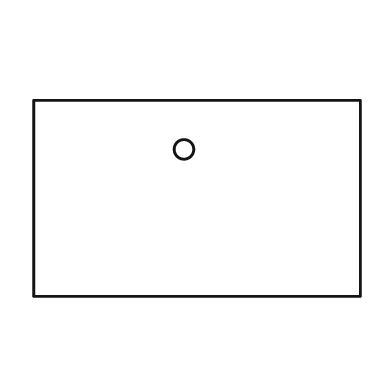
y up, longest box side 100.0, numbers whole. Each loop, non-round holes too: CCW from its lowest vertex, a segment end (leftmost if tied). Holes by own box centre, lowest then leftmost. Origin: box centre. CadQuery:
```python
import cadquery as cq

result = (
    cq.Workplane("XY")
    .moveTo(-50.0, -30.0)
    .lineTo(50.0, -30.0)
    .lineTo(50.0, 30.0)
    .lineTo(-50.0, 30.0)
    .close()
    .moveTo(-4.0, 15.0)
    .circle(3.0)
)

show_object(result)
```